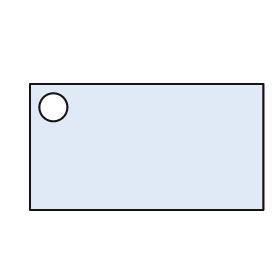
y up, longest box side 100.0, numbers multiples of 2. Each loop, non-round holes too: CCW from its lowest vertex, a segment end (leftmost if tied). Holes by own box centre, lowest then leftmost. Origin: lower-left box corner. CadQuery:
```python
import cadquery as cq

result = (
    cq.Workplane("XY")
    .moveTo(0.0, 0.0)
    .lineTo(100.0, 0.0)
    .lineTo(100.0, 54.0)
    .lineTo(0.0, 54.0)
    .close()
    .moveTo(10.0, 44.0)
    .circle(6.0)
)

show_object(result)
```